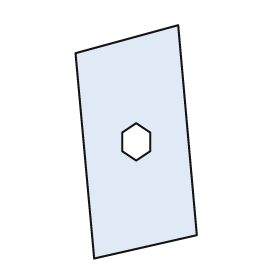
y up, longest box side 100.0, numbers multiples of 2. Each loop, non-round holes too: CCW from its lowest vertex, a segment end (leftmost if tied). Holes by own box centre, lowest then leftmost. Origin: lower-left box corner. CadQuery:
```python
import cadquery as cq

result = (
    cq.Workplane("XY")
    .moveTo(8.0, 0.0)
    .lineTo(52.0, 10.0)
    .lineTo(44.0, 100.0)
    .lineTo(0.0, 88.0)
    .close()
    .moveTo(26.0, 42.0)
    .lineTo(32.0, 46.0)
    .lineTo(32.0, 54.0)
    .lineTo(26.0, 58.0)
    .lineTo(20.0, 54.0)
    .lineTo(20.0, 46.0)
    .close()
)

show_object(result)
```